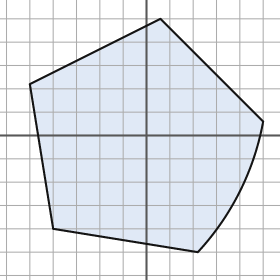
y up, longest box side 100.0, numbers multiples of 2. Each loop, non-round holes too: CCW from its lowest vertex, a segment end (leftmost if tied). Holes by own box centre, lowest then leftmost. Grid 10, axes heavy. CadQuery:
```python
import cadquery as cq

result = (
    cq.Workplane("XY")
    .moveTo(22.0, -50.0)
    .threePointArc((40.0, -24.0), (50.0, 6.0))
    .lineTo(6.0, 50.0)
    .lineTo(-50.0, 22.0)
    .lineTo(-40.0, -40.0)
    .close()
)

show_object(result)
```